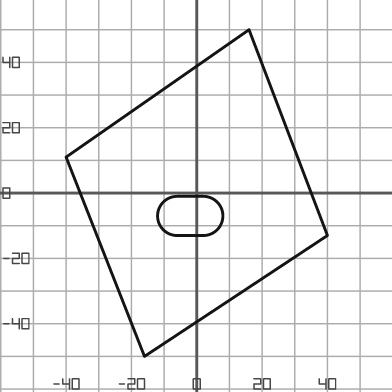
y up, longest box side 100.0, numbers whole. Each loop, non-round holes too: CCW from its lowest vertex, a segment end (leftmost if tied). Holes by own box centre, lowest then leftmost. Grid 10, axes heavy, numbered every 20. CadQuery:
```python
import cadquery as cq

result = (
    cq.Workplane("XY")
    .moveTo(-16.0, -50.0)
    .lineTo(40.0, -13.0)
    .lineTo(16.0, 50.0)
    .lineTo(-40.0, 11.0)
    .close()
    .moveTo(-6.0, -13.0)
    .lineTo(2.0, -13.0)
    .threePointArc((8.0, -7.0), (2.0, -1.0))
    .lineTo(-6.0, -1.0)
    .threePointArc((-12.0, -7.0), (-6.0, -13.0))
    .close()
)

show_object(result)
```